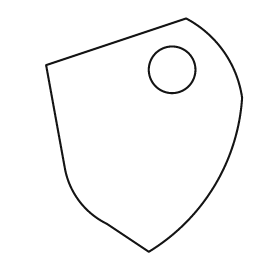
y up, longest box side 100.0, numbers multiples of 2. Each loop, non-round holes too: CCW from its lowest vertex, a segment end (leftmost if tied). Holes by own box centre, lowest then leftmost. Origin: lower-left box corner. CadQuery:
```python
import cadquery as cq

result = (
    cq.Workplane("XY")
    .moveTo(44.0, 0.0)
    .threePointArc((72.0, 28.0), (84.0, 66.0))
    .threePointArc((76.0, 86.0), (60.0, 100.0))
    .lineTo(0.0, 80.0)
    .lineTo(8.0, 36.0)
    .threePointArc((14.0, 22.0), (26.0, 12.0))
    .close()
    .moveTo(54.0, 78.0)
    .circle(10.0)
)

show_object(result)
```